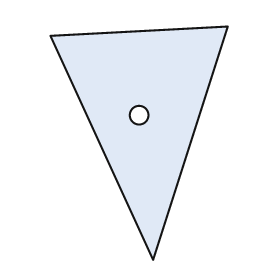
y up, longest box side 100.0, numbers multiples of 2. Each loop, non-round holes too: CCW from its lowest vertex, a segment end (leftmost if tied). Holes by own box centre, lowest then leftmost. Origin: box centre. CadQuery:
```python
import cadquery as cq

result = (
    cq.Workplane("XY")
    .moveTo(6.0, -50.0)
    .lineTo(38.0, 50.0)
    .lineTo(-38.0, 46.0)
    .close()
    .moveTo(0.0, 12.0)
    .circle(4.0)
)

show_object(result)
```